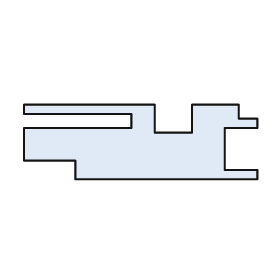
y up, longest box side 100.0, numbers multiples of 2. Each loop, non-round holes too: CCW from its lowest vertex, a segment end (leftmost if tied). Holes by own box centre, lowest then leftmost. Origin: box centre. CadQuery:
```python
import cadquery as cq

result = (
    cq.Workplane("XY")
    .moveTo(-28.0, -16.0)
    .lineTo(50.0, -16.0)
    .lineTo(50.0, -12.0)
    .lineTo(36.0, -12.0)
    .lineTo(36.0, 6.0)
    .lineTo(50.0, 6.0)
    .lineTo(50.0, 10.0)
    .lineTo(42.0, 10.0)
    .lineTo(42.0, 16.0)
    .lineTo(22.0, 16.0)
    .lineTo(22.0, 4.0)
    .lineTo(6.0, 4.0)
    .lineTo(6.0, 16.0)
    .lineTo(-50.0, 16.0)
    .lineTo(-50.0, 12.0)
    .lineTo(-4.0, 12.0)
    .lineTo(-4.0, 6.0)
    .lineTo(-50.0, 6.0)
    .lineTo(-50.0, -8.0)
    .lineTo(-28.0, -8.0)
    .close()
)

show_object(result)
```